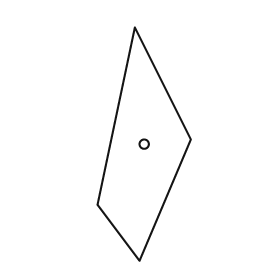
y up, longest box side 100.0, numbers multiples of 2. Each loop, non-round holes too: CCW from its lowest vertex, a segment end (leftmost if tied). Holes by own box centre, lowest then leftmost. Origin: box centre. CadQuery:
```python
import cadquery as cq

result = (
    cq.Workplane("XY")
    .moveTo(-2.0, -50.0)
    .lineTo(20.0, 2.0)
    .lineTo(-4.0, 50.0)
    .lineTo(-20.0, -26.0)
    .close()
    .moveTo(0.0, 0.0)
    .circle(2.0)
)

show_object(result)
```